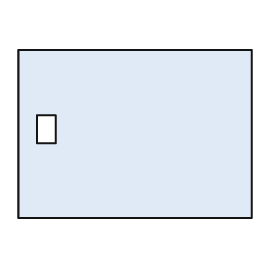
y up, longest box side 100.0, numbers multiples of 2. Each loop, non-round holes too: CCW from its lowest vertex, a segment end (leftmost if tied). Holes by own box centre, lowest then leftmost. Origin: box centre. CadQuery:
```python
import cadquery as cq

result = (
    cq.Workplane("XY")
    .moveTo(-50.0, -36.0)
    .lineTo(50.0, -36.0)
    .lineTo(50.0, 36.0)
    .lineTo(-50.0, 36.0)
    .close()
    .moveTo(-42.0, -4.0)
    .lineTo(-34.0, -4.0)
    .lineTo(-34.0, 8.0)
    .lineTo(-42.0, 8.0)
    .close()
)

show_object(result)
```